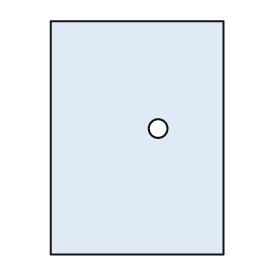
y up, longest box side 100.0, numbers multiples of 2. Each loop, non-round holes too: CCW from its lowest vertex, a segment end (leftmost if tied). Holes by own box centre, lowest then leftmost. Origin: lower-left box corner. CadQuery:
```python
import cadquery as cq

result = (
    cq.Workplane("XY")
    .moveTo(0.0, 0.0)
    .lineTo(74.0, 0.0)
    .lineTo(74.0, 100.0)
    .lineTo(0.0, 100.0)
    .close()
    .moveTo(46.0, 54.0)
    .circle(4.0)
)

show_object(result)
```